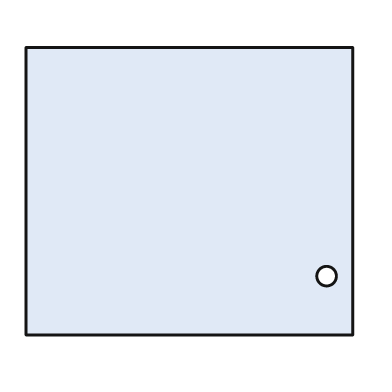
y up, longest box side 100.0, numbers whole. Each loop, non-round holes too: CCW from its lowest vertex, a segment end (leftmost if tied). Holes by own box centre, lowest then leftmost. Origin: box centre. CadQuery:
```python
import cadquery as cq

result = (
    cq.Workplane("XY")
    .moveTo(-50.0, -44.0)
    .lineTo(50.0, -44.0)
    .lineTo(50.0, 44.0)
    .lineTo(-50.0, 44.0)
    .close()
    .moveTo(42.0, -26.0)
    .circle(3.0)
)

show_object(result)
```